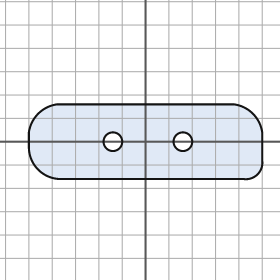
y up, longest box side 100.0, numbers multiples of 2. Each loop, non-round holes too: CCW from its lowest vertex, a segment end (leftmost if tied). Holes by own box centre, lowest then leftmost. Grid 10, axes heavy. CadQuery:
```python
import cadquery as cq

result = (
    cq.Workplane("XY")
    .moveTo(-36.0, -16.0)
    .lineTo(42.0, -16.0)
    .threePointArc((48.0, -14.0), (50.0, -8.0))
    .lineTo(50.0, 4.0)
    .threePointArc((46.0, 12.0), (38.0, 16.0))
    .lineTo(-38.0, 16.0)
    .threePointArc((-46.0, 12.0), (-50.0, 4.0))
    .lineTo(-50.0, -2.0)
    .threePointArc((-46.0, -12.0), (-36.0, -16.0))
    .close()
    .moveTo(-14.0, 0.0)
    .circle(4.0)
    .moveTo(16.0, 0.0)
    .circle(4.0)
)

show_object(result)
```